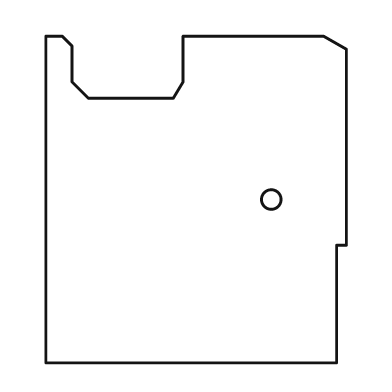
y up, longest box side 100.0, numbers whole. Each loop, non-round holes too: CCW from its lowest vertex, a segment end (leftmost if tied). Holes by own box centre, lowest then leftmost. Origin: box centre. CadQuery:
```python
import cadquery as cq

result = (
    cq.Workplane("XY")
    .moveTo(-46.0, -50.0)
    .lineTo(43.0, -50.0)
    .lineTo(43.0, -14.0)
    .lineTo(46.0, -14.0)
    .lineTo(46.0, 46.0)
    .lineTo(39.0, 50.0)
    .lineTo(-4.0, 50.0)
    .lineTo(-4.0, 36.0)
    .lineTo(-7.0, 31.0)
    .lineTo(-33.0, 31.0)
    .lineTo(-38.0, 36.0)
    .lineTo(-38.0, 47.0)
    .lineTo(-41.0, 50.0)
    .lineTo(-46.0, 50.0)
    .close()
    .moveTo(23.0, 0.0)
    .circle(3.0)
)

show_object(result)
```